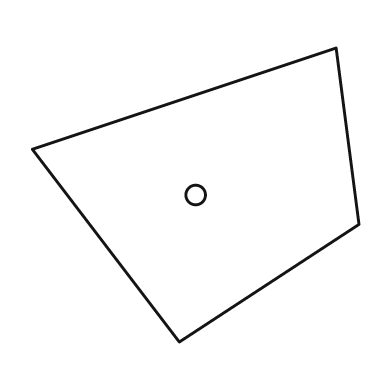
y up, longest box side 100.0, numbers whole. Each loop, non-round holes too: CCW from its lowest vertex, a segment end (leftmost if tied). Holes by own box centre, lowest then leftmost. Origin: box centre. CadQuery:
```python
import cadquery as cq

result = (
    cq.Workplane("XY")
    .moveTo(-5.0, -45.0)
    .lineTo(50.0, -9.0)
    .lineTo(43.0, 45.0)
    .lineTo(-50.0, 14.0)
    .close()
    .moveTo(0.0, 0.0)
    .circle(3.0)
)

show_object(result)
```